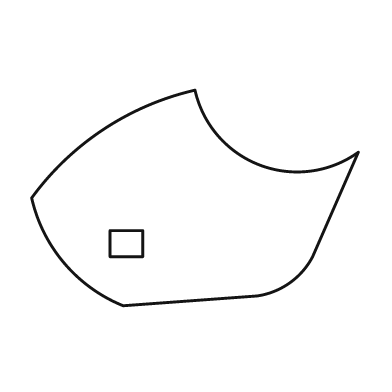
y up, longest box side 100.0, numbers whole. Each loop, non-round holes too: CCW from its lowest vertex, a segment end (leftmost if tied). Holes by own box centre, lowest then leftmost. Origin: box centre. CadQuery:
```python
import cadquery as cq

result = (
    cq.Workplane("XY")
    .moveTo(-22.0, -33.0)
    .lineTo(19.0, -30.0)
    .threePointArc((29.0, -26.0), (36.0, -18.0))
    .lineTo(50.0, 14.0)
    .threePointArc((20.0, 10.0), (0.0, 33.0))
    .threePointArc((-28.0, 21.0), (-50.0, 0.0))
    .threePointArc((-40.0, -20.0), (-22.0, -33.0))
    .close()
    .moveTo(-26.0, -18.0)
    .lineTo(-16.0, -18.0)
    .lineTo(-16.0, -10.0)
    .lineTo(-26.0, -10.0)
    .close()
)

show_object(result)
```